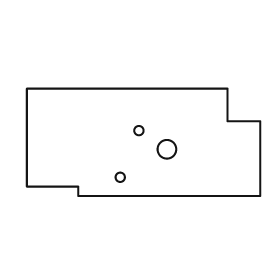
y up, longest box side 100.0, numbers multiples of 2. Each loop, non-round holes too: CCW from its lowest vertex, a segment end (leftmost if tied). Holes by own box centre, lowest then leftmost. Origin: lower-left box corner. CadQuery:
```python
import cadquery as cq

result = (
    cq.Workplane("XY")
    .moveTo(22.0, 0.0)
    .lineTo(100.0, 0.0)
    .lineTo(100.0, 32.0)
    .lineTo(86.0, 32.0)
    .lineTo(86.0, 46.0)
    .lineTo(0.0, 46.0)
    .lineTo(0.0, 4.0)
    .lineTo(22.0, 4.0)
    .close()
    .moveTo(40.0, 8.0)
    .circle(2.0)
    .moveTo(60.0, 20.0)
    .circle(4.0)
    .moveTo(48.0, 28.0)
    .circle(2.0)
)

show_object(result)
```